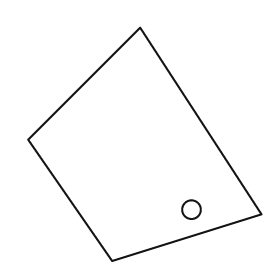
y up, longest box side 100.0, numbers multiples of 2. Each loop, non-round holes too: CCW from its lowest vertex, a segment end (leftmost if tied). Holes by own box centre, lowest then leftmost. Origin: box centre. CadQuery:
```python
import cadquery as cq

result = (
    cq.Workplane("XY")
    .moveTo(-14.0, -50.0)
    .lineTo(50.0, -30.0)
    .lineTo(-2.0, 50.0)
    .lineTo(-50.0, 2.0)
    .close()
    .moveTo(20.0, -28.0)
    .circle(4.0)
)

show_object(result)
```